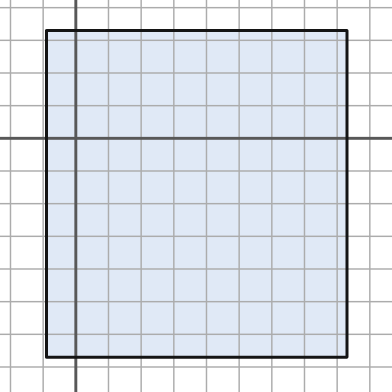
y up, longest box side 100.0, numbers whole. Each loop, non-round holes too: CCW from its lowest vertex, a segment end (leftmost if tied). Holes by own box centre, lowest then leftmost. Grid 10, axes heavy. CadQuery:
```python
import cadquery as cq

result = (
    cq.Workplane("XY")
    .moveTo(-9.0, -67.0)
    .lineTo(83.0, -67.0)
    .lineTo(83.0, 33.0)
    .lineTo(-9.0, 33.0)
    .close()
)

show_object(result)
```